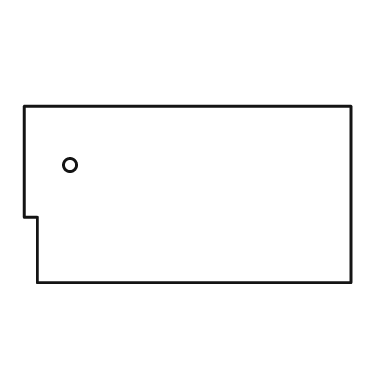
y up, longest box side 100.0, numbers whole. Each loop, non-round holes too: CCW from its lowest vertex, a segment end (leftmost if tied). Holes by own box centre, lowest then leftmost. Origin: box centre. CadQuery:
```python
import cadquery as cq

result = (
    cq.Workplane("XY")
    .moveTo(-46.0, -27.0)
    .lineTo(50.0, -27.0)
    .lineTo(50.0, 27.0)
    .lineTo(-50.0, 27.0)
    .lineTo(-50.0, -7.0)
    .lineTo(-46.0, -7.0)
    .close()
    .moveTo(-36.0, 9.0)
    .circle(2.0)
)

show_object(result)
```